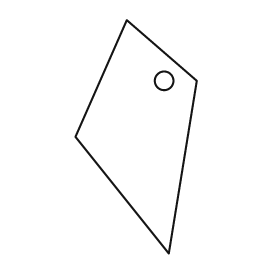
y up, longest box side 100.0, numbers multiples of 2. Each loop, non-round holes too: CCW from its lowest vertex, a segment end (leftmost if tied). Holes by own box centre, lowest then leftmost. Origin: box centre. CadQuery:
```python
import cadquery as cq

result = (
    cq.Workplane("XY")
    .moveTo(14.0, -50.0)
    .lineTo(26.0, 24.0)
    .lineTo(-4.0, 50.0)
    .lineTo(-26.0, 0.0)
    .close()
    .moveTo(12.0, 24.0)
    .circle(4.0)
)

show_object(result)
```